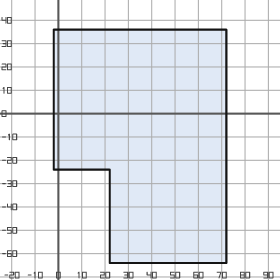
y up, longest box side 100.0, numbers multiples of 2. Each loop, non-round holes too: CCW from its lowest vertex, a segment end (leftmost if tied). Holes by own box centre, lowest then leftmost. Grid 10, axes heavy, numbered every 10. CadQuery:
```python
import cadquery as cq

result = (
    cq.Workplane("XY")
    .moveTo(22.0, -64.0)
    .lineTo(72.0, -64.0)
    .lineTo(72.0, 36.0)
    .lineTo(-2.0, 36.0)
    .lineTo(-2.0, -24.0)
    .lineTo(22.0, -24.0)
    .close()
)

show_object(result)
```